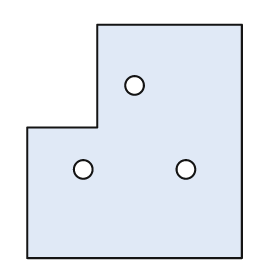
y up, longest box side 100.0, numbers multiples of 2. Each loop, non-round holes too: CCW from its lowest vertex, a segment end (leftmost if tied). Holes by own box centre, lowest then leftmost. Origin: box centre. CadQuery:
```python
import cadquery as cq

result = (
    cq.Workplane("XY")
    .moveTo(-46.0, -50.0)
    .lineTo(46.0, -50.0)
    .lineTo(46.0, 50.0)
    .lineTo(-16.0, 50.0)
    .lineTo(-16.0, 6.0)
    .lineTo(-46.0, 6.0)
    .close()
    .moveTo(-22.0, -12.0)
    .circle(4.0)
    .moveTo(22.0, -12.0)
    .circle(4.0)
    .moveTo(0.0, 24.0)
    .circle(4.0)
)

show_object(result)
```